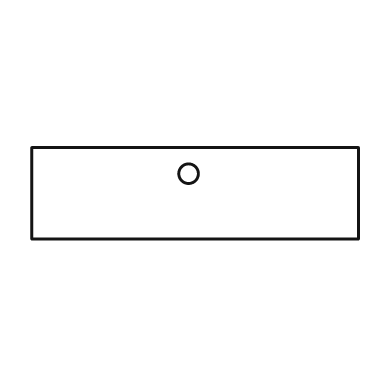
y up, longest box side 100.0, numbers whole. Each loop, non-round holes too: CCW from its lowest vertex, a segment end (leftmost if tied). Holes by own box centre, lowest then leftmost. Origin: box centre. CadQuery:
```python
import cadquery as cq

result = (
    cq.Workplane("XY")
    .moveTo(-50.0, -14.0)
    .lineTo(50.0, -14.0)
    .lineTo(50.0, 14.0)
    .lineTo(-50.0, 14.0)
    .close()
    .moveTo(-2.0, 6.0)
    .circle(3.0)
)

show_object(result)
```